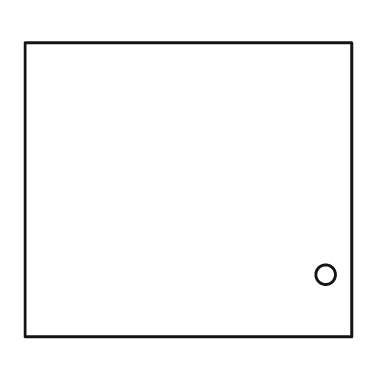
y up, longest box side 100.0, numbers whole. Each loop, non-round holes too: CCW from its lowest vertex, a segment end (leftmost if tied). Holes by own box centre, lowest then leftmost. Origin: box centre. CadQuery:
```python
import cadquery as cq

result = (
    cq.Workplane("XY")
    .moveTo(-50.0, -45.0)
    .lineTo(50.0, -45.0)
    .lineTo(50.0, 45.0)
    .lineTo(-50.0, 45.0)
    .close()
    .moveTo(42.0, -26.0)
    .circle(3.0)
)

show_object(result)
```